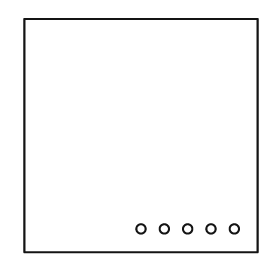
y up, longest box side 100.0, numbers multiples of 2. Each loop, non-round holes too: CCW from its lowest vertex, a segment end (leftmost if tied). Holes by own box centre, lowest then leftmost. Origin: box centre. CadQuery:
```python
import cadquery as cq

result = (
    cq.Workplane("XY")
    .moveTo(-50.0, -50.0)
    .lineTo(50.0, -50.0)
    .lineTo(50.0, 50.0)
    .lineTo(-50.0, 50.0)
    .close()
    .moveTo(0.0, -40.0)
    .circle(2.0)
    .moveTo(10.0, -40.0)
    .circle(2.0)
    .moveTo(20.0, -40.0)
    .circle(2.0)
    .moveTo(30.0, -40.0)
    .circle(2.0)
    .moveTo(40.0, -40.0)
    .circle(2.0)
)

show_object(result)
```